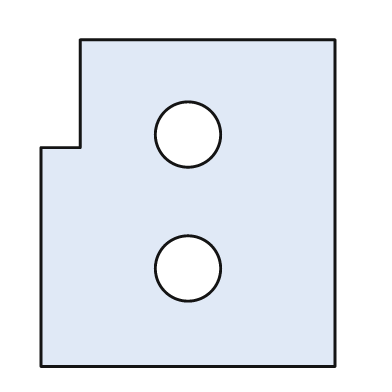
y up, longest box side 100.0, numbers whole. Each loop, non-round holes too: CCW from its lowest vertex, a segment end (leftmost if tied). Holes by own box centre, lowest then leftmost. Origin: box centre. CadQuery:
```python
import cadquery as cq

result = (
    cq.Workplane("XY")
    .moveTo(-45.0, -50.0)
    .lineTo(45.0, -50.0)
    .lineTo(45.0, 50.0)
    .lineTo(-33.0, 50.0)
    .lineTo(-33.0, 17.0)
    .lineTo(-45.0, 17.0)
    .close()
    .moveTo(0.0, -20.0)
    .circle(10.0)
    .moveTo(0.0, 21.0)
    .circle(10.0)
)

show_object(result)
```